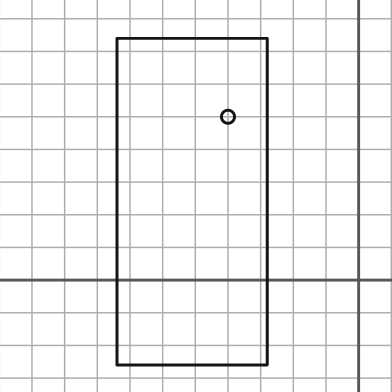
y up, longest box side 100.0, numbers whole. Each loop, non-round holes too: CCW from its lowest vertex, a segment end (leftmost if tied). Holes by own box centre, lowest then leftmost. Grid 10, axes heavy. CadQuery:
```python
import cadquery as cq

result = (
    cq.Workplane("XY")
    .moveTo(-74.0, -26.0)
    .lineTo(-28.0, -26.0)
    .lineTo(-28.0, 74.0)
    .lineTo(-74.0, 74.0)
    .close()
    .moveTo(-40.0, 50.0)
    .circle(2.0)
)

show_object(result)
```